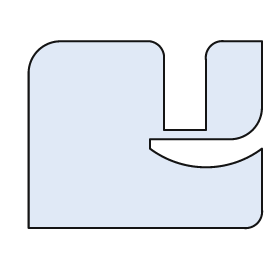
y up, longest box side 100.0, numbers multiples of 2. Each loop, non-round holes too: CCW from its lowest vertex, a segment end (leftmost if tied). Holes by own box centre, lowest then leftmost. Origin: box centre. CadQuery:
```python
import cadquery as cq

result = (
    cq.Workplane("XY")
    .moveTo(-50.0, -40.0)
    .lineTo(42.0, -40.0)
    .threePointArc((48.0, -38.0), (50.0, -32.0))
    .lineTo(50.0, -6.0)
    .threePointArc((26.0, -14.0), (2.0, -6.0))
    .lineTo(2.0, -2.0)
    .lineTo(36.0, -2.0)
    .threePointArc((46.0, 2.0), (50.0, 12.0))
    .lineTo(50.0, 40.0)
    .lineTo(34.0, 40.0)
    .threePointArc((28.0, 38.0), (26.0, 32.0))
    .lineTo(26.0, 2.0)
    .lineTo(8.0, 2.0)
    .lineTo(8.0, 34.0)
    .threePointArc((6.0, 38.0), (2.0, 40.0))
    .lineTo(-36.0, 40.0)
    .threePointArc((-46.0, 36.0), (-50.0, 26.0))
    .close()
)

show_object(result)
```